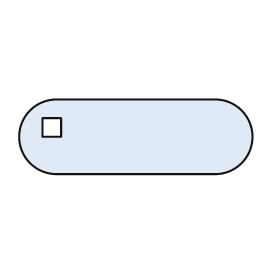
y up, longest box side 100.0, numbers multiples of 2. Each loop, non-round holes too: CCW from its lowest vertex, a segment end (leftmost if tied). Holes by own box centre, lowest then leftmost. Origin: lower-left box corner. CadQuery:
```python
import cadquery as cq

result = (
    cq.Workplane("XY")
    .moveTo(16.0, 0.0)
    .lineTo(84.0, 0.0)
    .threePointArc((100.0, 16.0), (84.0, 32.0))
    .lineTo(16.0, 32.0)
    .threePointArc((0.0, 16.0), (16.0, 0.0))
    .close()
    .moveTo(10.0, 16.0)
    .lineTo(18.0, 16.0)
    .lineTo(18.0, 24.0)
    .lineTo(10.0, 24.0)
    .close()
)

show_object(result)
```